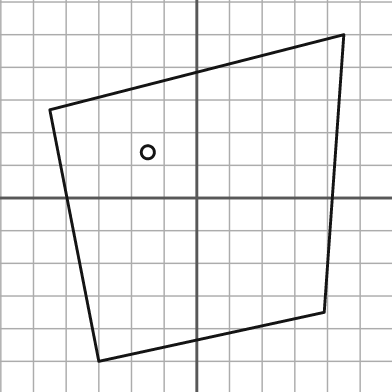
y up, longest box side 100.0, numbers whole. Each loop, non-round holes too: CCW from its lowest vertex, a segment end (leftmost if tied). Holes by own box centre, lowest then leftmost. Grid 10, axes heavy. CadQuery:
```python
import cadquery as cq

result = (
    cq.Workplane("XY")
    .moveTo(-30.0, -50.0)
    .lineTo(39.0, -35.0)
    .lineTo(45.0, 50.0)
    .lineTo(-45.0, 27.0)
    .close()
    .moveTo(-15.0, 14.0)
    .circle(2.0)
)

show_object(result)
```